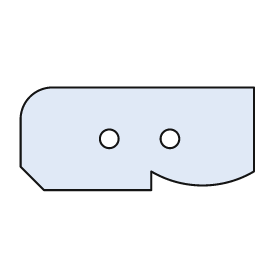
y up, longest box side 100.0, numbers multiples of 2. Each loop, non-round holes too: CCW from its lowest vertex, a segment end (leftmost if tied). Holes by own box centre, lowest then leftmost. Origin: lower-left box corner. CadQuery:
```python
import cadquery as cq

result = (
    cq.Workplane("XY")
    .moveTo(10.0, 0.0)
    .lineTo(56.0, 0.0)
    .lineTo(56.0, 8.0)
    .threePointArc((78.0, 2.0), (100.0, 8.0))
    .lineTo(100.0, 44.0)
    .lineTo(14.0, 44.0)
    .threePointArc((4.0, 40.0), (0.0, 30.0))
    .lineTo(0.0, 10.0)
    .close()
    .moveTo(38.0, 22.0)
    .circle(4.0)
    .moveTo(64.0, 22.0)
    .circle(4.0)
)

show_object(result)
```